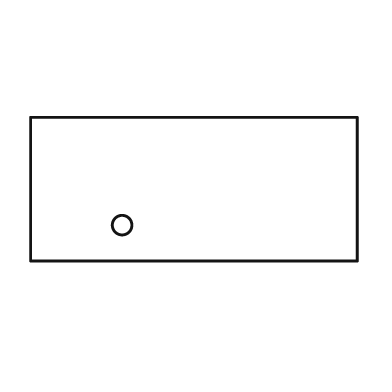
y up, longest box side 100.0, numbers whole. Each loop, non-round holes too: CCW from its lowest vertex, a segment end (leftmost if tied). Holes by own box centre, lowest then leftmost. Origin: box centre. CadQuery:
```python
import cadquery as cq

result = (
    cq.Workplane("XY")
    .moveTo(-50.0, -22.0)
    .lineTo(50.0, -22.0)
    .lineTo(50.0, 22.0)
    .lineTo(-50.0, 22.0)
    .close()
    .moveTo(-22.0, -11.0)
    .circle(3.0)
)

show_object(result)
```